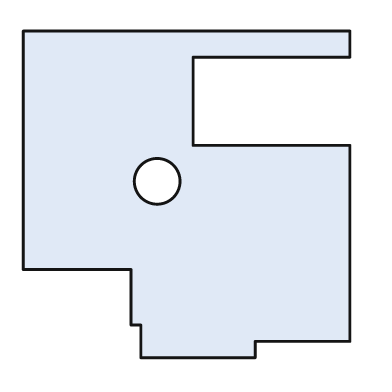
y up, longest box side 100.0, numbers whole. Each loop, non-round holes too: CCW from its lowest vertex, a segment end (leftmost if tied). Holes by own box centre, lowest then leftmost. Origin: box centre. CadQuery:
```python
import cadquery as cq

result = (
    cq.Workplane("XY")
    .moveTo(-14.0, -50.0)
    .lineTo(21.0, -50.0)
    .lineTo(21.0, -45.0)
    .lineTo(50.0, -45.0)
    .lineTo(50.0, 15.0)
    .lineTo(2.0, 15.0)
    .lineTo(2.0, 42.0)
    .lineTo(50.0, 42.0)
    .lineTo(50.0, 50.0)
    .lineTo(-50.0, 50.0)
    .lineTo(-50.0, -23.0)
    .lineTo(-17.0, -23.0)
    .lineTo(-17.0, -40.0)
    .lineTo(-14.0, -40.0)
    .close()
    .moveTo(-9.0, 4.0)
    .circle(7.0)
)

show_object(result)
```